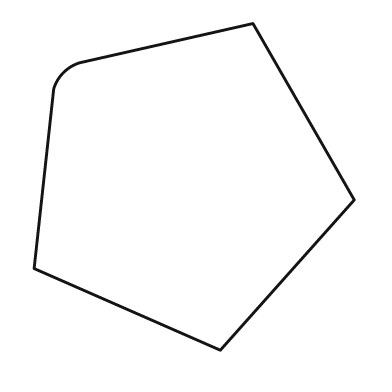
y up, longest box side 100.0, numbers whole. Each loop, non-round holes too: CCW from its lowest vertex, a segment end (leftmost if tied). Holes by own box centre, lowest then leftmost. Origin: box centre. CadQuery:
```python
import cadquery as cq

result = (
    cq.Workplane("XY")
    .moveTo(8.0, -50.0)
    .lineTo(49.0, -4.0)
    .lineTo(18.0, 50.0)
    .lineTo(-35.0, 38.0)
    .threePointArc((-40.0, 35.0), (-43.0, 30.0))
    .lineTo(-49.0, -25.0)
    .close()
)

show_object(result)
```